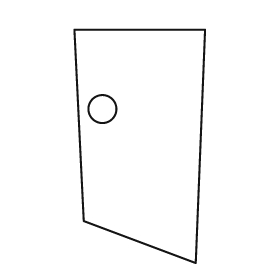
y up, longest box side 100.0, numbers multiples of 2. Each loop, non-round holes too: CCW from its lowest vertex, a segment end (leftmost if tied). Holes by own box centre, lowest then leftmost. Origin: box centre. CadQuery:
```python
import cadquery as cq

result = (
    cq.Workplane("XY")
    .moveTo(24.0, -50.0)
    .lineTo(28.0, 50.0)
    .lineTo(-28.0, 50.0)
    .lineTo(-24.0, -32.0)
    .close()
    .moveTo(-16.0, 16.0)
    .circle(6.0)
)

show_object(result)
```